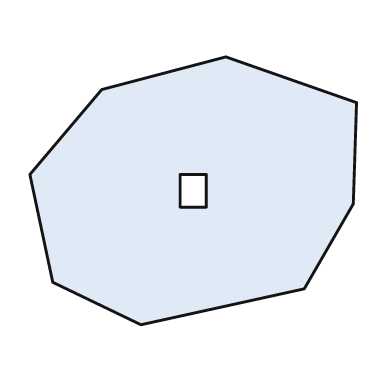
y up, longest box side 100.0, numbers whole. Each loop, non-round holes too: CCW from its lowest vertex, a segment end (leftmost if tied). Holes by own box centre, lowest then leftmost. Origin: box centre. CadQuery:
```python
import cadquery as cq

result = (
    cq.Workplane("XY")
    .moveTo(-16.0, -41.0)
    .lineTo(34.0, -30.0)
    .lineTo(49.0, -4.0)
    .lineTo(50.0, 27.0)
    .lineTo(10.0, 41.0)
    .lineTo(-28.0, 31.0)
    .lineTo(-50.0, 5.0)
    .lineTo(-43.0, -28.0)
    .close()
    .moveTo(-4.0, -5.0)
    .lineTo(4.0, -5.0)
    .lineTo(4.0, 5.0)
    .lineTo(-4.0, 5.0)
    .close()
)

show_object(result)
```